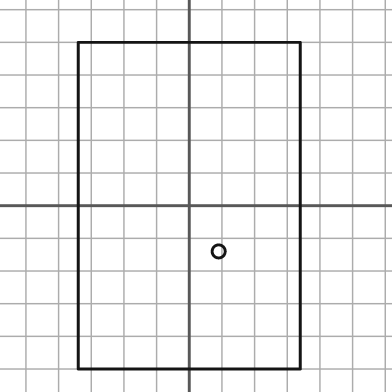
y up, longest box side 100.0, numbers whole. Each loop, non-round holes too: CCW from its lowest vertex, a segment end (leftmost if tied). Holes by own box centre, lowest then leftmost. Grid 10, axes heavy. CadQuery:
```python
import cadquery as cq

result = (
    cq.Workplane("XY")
    .moveTo(-34.0, -50.0)
    .lineTo(34.0, -50.0)
    .lineTo(34.0, 50.0)
    .lineTo(-34.0, 50.0)
    .close()
    .moveTo(9.0, -14.0)
    .circle(2.0)
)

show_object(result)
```